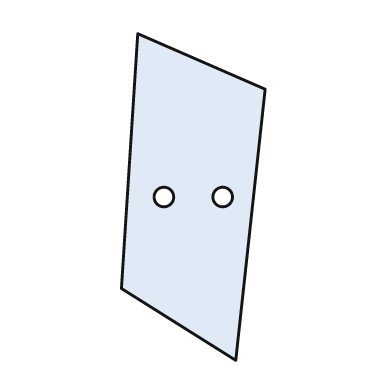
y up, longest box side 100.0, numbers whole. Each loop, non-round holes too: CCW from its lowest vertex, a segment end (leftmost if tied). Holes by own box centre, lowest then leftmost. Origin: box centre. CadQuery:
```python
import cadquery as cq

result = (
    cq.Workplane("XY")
    .moveTo(13.0, -50.0)
    .lineTo(22.0, 33.0)
    .lineTo(-17.0, 50.0)
    .lineTo(-22.0, -28.0)
    .close()
    .moveTo(-9.0, 0.0)
    .circle(3.0)
    .moveTo(9.0, 0.0)
    .circle(3.0)
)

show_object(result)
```